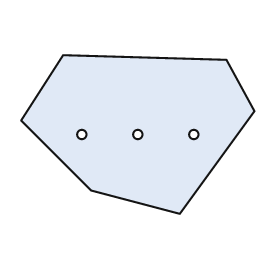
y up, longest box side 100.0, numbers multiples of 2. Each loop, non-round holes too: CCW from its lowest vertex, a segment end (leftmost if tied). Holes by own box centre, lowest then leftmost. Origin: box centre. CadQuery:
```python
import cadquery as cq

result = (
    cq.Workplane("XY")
    .moveTo(18.0, -34.0)
    .lineTo(50.0, 10.0)
    .lineTo(38.0, 32.0)
    .lineTo(-32.0, 34.0)
    .lineTo(-50.0, 6.0)
    .lineTo(-20.0, -24.0)
    .close()
    .moveTo(-24.0, 0.0)
    .circle(2.0)
    .moveTo(0.0, 0.0)
    .circle(2.0)
    .moveTo(24.0, 0.0)
    .circle(2.0)
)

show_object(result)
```